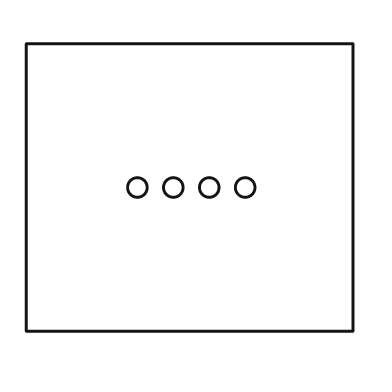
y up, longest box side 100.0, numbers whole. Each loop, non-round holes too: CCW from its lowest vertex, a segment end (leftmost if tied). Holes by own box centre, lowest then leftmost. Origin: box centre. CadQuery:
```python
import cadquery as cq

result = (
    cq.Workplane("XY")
    .moveTo(-50.0, -44.0)
    .lineTo(50.0, -44.0)
    .lineTo(50.0, 44.0)
    .lineTo(-50.0, 44.0)
    .close()
    .moveTo(-16.0, 0.0)
    .circle(3.0)
    .moveTo(-5.0, 0.0)
    .circle(3.0)
    .moveTo(6.0, 0.0)
    .circle(3.0)
    .moveTo(17.0, 0.0)
    .circle(3.0)
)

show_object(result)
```